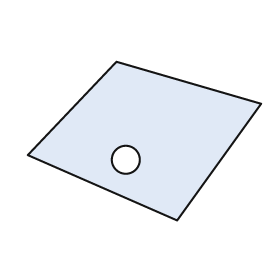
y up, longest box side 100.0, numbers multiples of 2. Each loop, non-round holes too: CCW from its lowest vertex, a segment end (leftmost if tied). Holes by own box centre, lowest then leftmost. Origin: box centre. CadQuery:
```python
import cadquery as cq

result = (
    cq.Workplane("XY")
    .moveTo(14.0, -34.0)
    .lineTo(50.0, 16.0)
    .lineTo(-12.0, 34.0)
    .lineTo(-50.0, -6.0)
    .close()
    .moveTo(-8.0, -8.0)
    .circle(6.0)
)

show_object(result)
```